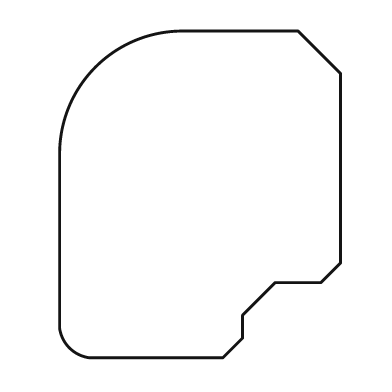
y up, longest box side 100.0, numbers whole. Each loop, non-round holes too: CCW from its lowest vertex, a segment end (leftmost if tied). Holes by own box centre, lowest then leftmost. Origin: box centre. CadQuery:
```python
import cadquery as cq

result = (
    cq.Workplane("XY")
    .moveTo(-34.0, -50.0)
    .lineTo(7.0, -50.0)
    .lineTo(13.0, -44.0)
    .lineTo(13.0, -37.0)
    .lineTo(23.0, -27.0)
    .lineTo(37.0, -27.0)
    .lineTo(43.0, -21.0)
    .lineTo(43.0, 37.0)
    .lineTo(30.0, 50.0)
    .lineTo(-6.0, 50.0)
    .threePointArc((-32.0, 39.0), (-43.0, 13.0))
    .lineTo(-43.0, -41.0)
    .threePointArc((-40.0, -47.0), (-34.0, -50.0))
    .close()
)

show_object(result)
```